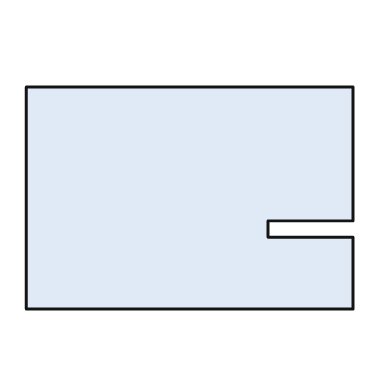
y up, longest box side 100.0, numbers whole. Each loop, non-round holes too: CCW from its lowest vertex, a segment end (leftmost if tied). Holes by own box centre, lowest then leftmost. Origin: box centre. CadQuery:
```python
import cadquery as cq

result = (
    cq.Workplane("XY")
    .moveTo(-50.0, -34.0)
    .lineTo(50.0, -34.0)
    .lineTo(50.0, -12.0)
    .lineTo(24.0, -12.0)
    .lineTo(24.0, -7.0)
    .lineTo(50.0, -7.0)
    .lineTo(50.0, 34.0)
    .lineTo(-50.0, 34.0)
    .close()
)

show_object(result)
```